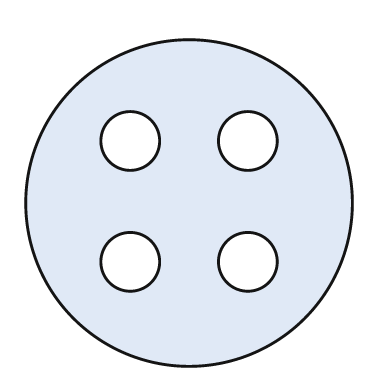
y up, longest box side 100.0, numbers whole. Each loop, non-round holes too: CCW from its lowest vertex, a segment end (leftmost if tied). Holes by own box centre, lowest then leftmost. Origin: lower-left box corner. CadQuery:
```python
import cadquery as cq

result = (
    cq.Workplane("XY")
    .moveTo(50.0, 50.0)
    .circle(50.0)
    .moveTo(32.0, 32.0)
    .circle(9.0)
    .moveTo(68.0, 32.0)
    .circle(9.0)
    .moveTo(32.0, 69.0)
    .circle(9.0)
    .moveTo(68.0, 69.0)
    .circle(9.0)
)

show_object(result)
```